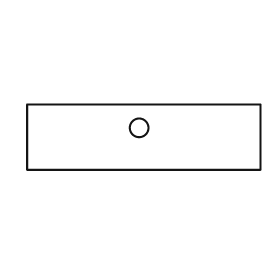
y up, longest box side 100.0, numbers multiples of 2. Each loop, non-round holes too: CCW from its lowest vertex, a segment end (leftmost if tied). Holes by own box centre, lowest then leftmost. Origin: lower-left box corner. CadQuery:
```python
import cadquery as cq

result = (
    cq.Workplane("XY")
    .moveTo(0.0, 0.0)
    .lineTo(100.0, 0.0)
    .lineTo(100.0, 28.0)
    .lineTo(0.0, 28.0)
    .close()
    .moveTo(48.0, 18.0)
    .circle(4.0)
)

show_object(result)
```